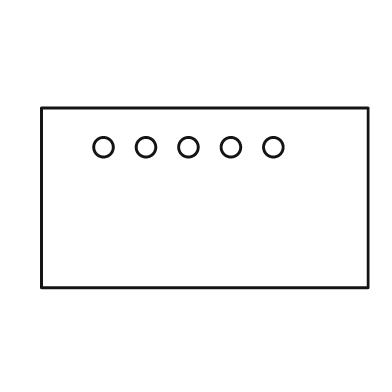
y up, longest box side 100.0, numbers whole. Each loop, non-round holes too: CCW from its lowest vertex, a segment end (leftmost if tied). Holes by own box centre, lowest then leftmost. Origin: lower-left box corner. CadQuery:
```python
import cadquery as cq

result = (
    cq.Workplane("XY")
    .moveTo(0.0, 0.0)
    .lineTo(100.0, 0.0)
    .lineTo(100.0, 55.0)
    .lineTo(0.0, 55.0)
    .close()
    .moveTo(19.0, 43.0)
    .circle(3.0)
    .moveTo(32.0, 43.0)
    .circle(3.0)
    .moveTo(45.0, 43.0)
    .circle(3.0)
    .moveTo(58.0, 43.0)
    .circle(3.0)
    .moveTo(71.0, 43.0)
    .circle(3.0)
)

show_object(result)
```